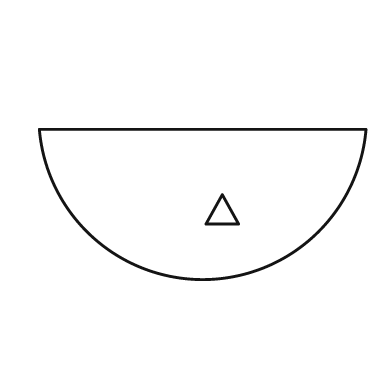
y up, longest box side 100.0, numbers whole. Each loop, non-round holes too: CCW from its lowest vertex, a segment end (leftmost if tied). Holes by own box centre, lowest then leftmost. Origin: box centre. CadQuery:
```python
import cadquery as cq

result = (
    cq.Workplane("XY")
    .moveTo(-50.0, 23.0)
    .threePointArc((0.0, -23.0), (50.0, 23.0))
    .close()
    .moveTo(1.0, -6.0)
    .lineTo(11.0, -6.0)
    .lineTo(6.0, 3.0)
    .close()
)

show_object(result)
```